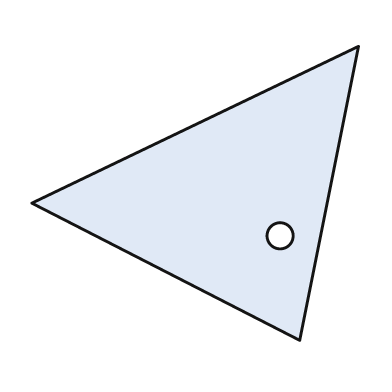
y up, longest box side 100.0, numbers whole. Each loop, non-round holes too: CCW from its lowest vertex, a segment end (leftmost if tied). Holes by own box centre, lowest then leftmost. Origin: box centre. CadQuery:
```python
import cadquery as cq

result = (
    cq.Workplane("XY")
    .moveTo(32.0, -45.0)
    .lineTo(50.0, 45.0)
    .lineTo(-50.0, -3.0)
    .close()
    .moveTo(26.0, -13.0)
    .circle(4.0)
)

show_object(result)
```